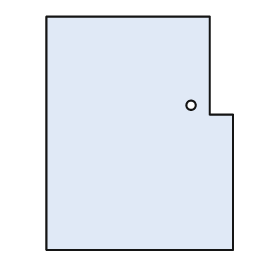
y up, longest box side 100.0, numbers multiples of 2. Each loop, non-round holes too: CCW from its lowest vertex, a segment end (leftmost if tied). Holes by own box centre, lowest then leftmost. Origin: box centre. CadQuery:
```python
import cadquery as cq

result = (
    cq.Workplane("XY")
    .moveTo(-40.0, -50.0)
    .lineTo(40.0, -50.0)
    .lineTo(40.0, 8.0)
    .lineTo(30.0, 8.0)
    .lineTo(30.0, 50.0)
    .lineTo(-40.0, 50.0)
    .close()
    .moveTo(22.0, 12.0)
    .circle(2.0)
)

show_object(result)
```